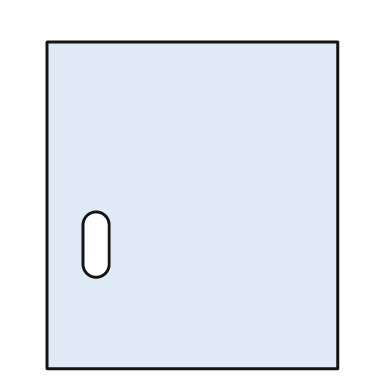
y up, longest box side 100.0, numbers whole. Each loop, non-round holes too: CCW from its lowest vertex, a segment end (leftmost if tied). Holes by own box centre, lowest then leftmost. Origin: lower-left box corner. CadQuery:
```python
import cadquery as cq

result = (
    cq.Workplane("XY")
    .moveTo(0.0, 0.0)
    .lineTo(89.0, 0.0)
    .lineTo(89.0, 100.0)
    .lineTo(0.0, 100.0)
    .close()
    .moveTo(11.0, 32.0)
    .threePointArc((15.0, 28.0), (19.0, 32.0))
    .lineTo(19.0, 44.0)
    .threePointArc((15.0, 48.0), (11.0, 44.0))
    .close()
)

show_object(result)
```